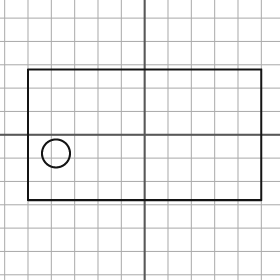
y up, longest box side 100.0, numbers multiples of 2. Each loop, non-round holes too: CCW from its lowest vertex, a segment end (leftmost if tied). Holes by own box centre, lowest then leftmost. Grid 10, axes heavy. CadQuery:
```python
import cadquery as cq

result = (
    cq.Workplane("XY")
    .moveTo(-50.0, -28.0)
    .lineTo(50.0, -28.0)
    .lineTo(50.0, 28.0)
    .lineTo(-50.0, 28.0)
    .close()
    .moveTo(-38.0, -8.0)
    .circle(6.0)
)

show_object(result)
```